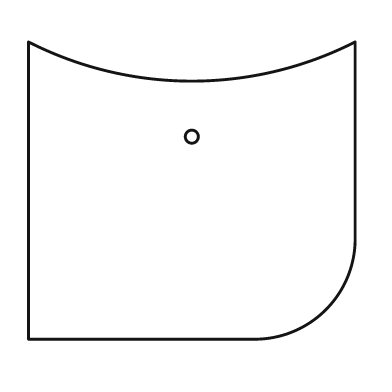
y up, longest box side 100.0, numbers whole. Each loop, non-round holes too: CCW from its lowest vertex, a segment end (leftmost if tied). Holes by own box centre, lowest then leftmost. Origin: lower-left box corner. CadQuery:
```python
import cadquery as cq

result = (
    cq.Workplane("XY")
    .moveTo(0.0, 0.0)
    .lineTo(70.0, 0.0)
    .threePointArc((91.0, 9.0), (100.0, 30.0))
    .lineTo(100.0, 91.0)
    .threePointArc((50.0, 79.0), (0.0, 91.0))
    .close()
    .moveTo(50.0, 62.0)
    .circle(2.0)
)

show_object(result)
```